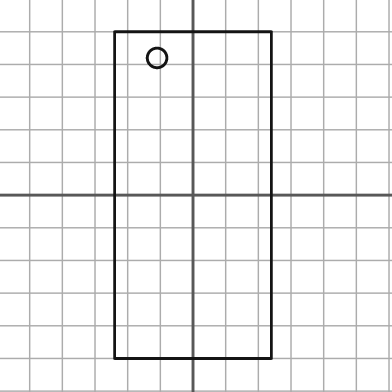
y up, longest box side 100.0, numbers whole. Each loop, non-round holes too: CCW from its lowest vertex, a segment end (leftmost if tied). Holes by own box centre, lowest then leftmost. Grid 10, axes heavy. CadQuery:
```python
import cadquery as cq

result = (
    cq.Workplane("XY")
    .moveTo(-24.0, -50.0)
    .lineTo(24.0, -50.0)
    .lineTo(24.0, 50.0)
    .lineTo(-24.0, 50.0)
    .close()
    .moveTo(-11.0, 42.0)
    .circle(3.0)
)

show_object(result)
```